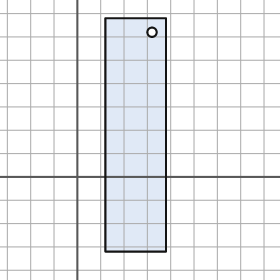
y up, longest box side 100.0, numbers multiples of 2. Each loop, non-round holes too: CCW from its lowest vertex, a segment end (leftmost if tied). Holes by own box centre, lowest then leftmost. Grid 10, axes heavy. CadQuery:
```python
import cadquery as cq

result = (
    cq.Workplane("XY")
    .moveTo(12.0, -32.0)
    .lineTo(38.0, -32.0)
    .lineTo(38.0, 68.0)
    .lineTo(12.0, 68.0)
    .close()
    .moveTo(32.0, 62.0)
    .circle(2.0)
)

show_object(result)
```